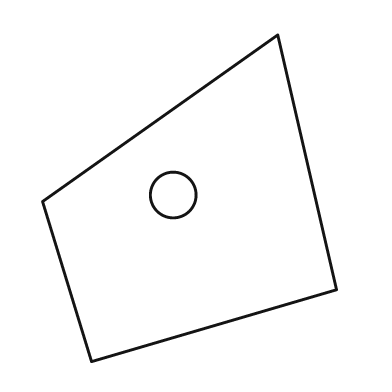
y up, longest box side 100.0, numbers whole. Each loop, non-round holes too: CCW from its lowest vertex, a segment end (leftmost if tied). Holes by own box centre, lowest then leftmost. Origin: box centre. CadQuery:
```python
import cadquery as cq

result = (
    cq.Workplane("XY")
    .moveTo(-30.0, -50.0)
    .lineTo(45.0, -28.0)
    .lineTo(27.0, 50.0)
    .lineTo(-45.0, -1.0)
    .close()
    .moveTo(-5.0, 1.0)
    .circle(7.0)
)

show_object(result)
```